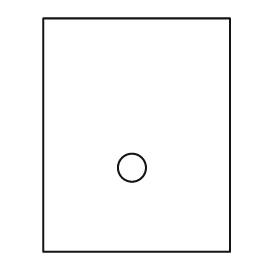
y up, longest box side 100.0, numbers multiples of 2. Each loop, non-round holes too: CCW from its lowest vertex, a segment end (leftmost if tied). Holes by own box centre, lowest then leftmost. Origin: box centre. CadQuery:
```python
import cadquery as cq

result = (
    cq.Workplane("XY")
    .moveTo(-40.0, -50.0)
    .lineTo(40.0, -50.0)
    .lineTo(40.0, 50.0)
    .lineTo(-40.0, 50.0)
    .close()
    .moveTo(-2.0, -14.0)
    .circle(6.0)
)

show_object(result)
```